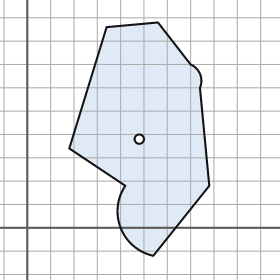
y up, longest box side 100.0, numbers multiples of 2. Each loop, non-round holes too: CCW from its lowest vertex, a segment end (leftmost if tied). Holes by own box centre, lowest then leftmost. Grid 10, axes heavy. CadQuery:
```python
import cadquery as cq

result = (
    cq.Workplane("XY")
    .moveTo(54.0, -12.0)
    .lineTo(78.0, 18.0)
    .lineTo(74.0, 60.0)
    .threePointArc((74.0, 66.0), (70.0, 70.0))
    .lineTo(56.0, 88.0)
    .lineTo(34.0, 86.0)
    .lineTo(18.0, 34.0)
    .lineTo(42.0, 18.0)
    .threePointArc((40.0, 0.0), (54.0, -12.0))
    .close()
    .moveTo(48.0, 38.0)
    .circle(2.0)
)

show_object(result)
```